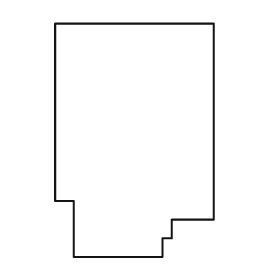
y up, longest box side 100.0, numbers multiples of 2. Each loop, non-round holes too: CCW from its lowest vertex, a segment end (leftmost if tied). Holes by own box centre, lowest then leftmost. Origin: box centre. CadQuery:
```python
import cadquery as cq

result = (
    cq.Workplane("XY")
    .moveTo(-26.0, -50.0)
    .lineTo(12.0, -50.0)
    .lineTo(12.0, -42.0)
    .lineTo(16.0, -42.0)
    .lineTo(16.0, -34.0)
    .lineTo(34.0, -34.0)
    .lineTo(34.0, 50.0)
    .lineTo(-34.0, 50.0)
    .lineTo(-34.0, -26.0)
    .lineTo(-26.0, -26.0)
    .close()
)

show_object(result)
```